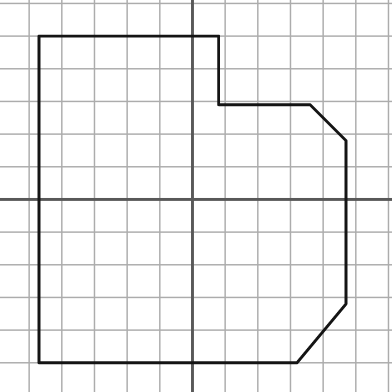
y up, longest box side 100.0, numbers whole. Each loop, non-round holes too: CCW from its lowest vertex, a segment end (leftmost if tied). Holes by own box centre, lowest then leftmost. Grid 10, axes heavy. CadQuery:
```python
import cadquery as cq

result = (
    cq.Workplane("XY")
    .moveTo(-47.0, -50.0)
    .lineTo(32.0, -50.0)
    .lineTo(47.0, -32.0)
    .lineTo(47.0, 18.0)
    .lineTo(36.0, 29.0)
    .lineTo(8.0, 29.0)
    .lineTo(8.0, 50.0)
    .lineTo(-47.0, 50.0)
    .close()
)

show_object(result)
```